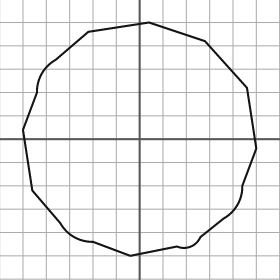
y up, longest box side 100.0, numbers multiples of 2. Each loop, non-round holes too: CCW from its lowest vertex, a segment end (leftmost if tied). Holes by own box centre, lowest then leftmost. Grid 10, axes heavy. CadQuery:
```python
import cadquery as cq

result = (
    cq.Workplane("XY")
    .moveTo(-4.0, -50.0)
    .lineTo(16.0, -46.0)
    .threePointArc((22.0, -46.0), (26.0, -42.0))
    .lineTo(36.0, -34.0)
    .threePointArc((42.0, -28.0), (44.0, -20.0))
    .lineTo(50.0, -4.0)
    .lineTo(46.0, 22.0)
    .lineTo(28.0, 42.0)
    .lineTo(4.0, 50.0)
    .lineTo(-22.0, 46.0)
    .lineTo(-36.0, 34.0)
    .threePointArc((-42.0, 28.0), (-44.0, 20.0))
    .lineTo(-50.0, 4.0)
    .lineTo(-46.0, -22.0)
    .lineTo(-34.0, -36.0)
    .threePointArc((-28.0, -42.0), (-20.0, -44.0))
    .close()
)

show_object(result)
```